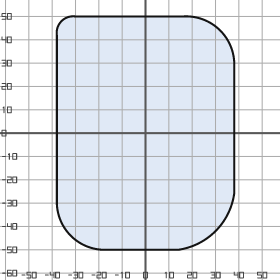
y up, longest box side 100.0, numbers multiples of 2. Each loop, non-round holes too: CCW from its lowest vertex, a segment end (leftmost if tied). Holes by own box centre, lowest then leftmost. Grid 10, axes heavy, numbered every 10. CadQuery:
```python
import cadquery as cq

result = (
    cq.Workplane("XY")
    .moveTo(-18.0, -50.0)
    .lineTo(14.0, -50.0)
    .threePointArc((30.0, -42.0), (38.0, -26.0))
    .lineTo(38.0, 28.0)
    .threePointArc((32.0, 44.0), (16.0, 50.0))
    .lineTo(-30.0, 50.0)
    .threePointArc((-36.0, 48.0), (-38.0, 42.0))
    .lineTo(-38.0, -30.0)
    .threePointArc((-32.0, -44.0), (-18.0, -50.0))
    .close()
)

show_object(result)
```